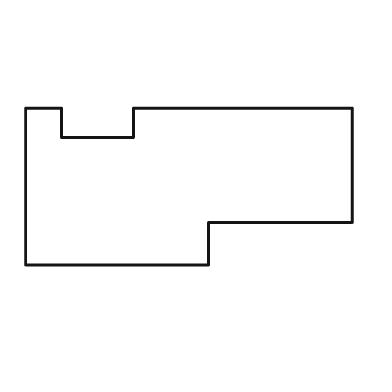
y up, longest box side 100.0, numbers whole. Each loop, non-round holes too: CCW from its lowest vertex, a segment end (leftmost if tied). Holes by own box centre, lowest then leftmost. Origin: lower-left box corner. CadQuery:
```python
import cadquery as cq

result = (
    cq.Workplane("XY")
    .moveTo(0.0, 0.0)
    .lineTo(56.0, 0.0)
    .lineTo(56.0, 13.0)
    .lineTo(100.0, 13.0)
    .lineTo(100.0, 48.0)
    .lineTo(33.0, 48.0)
    .lineTo(33.0, 39.0)
    .lineTo(11.0, 39.0)
    .lineTo(11.0, 48.0)
    .lineTo(0.0, 48.0)
    .close()
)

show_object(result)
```